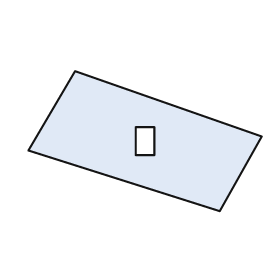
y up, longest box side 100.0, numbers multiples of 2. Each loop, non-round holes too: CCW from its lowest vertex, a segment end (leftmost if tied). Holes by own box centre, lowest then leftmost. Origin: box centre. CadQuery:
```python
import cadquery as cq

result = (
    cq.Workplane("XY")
    .moveTo(32.0, -30.0)
    .lineTo(50.0, 2.0)
    .lineTo(-30.0, 30.0)
    .lineTo(-50.0, -4.0)
    .close()
    .moveTo(-4.0, -6.0)
    .lineTo(4.0, -6.0)
    .lineTo(4.0, 6.0)
    .lineTo(-4.0, 6.0)
    .close()
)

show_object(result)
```